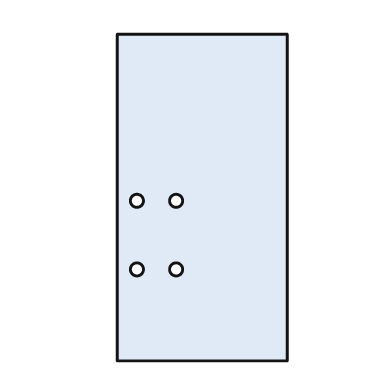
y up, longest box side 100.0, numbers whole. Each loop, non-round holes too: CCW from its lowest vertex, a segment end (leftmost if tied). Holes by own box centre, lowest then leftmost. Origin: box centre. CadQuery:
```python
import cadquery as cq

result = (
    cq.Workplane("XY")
    .moveTo(-26.0, -50.0)
    .lineTo(26.0, -50.0)
    .lineTo(26.0, 50.0)
    .lineTo(-26.0, 50.0)
    .close()
    .moveTo(-20.0, -22.0)
    .circle(2.0)
    .moveTo(-8.0, -22.0)
    .circle(2.0)
    .moveTo(-20.0, -1.0)
    .circle(2.0)
    .moveTo(-8.0, -1.0)
    .circle(2.0)
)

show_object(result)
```